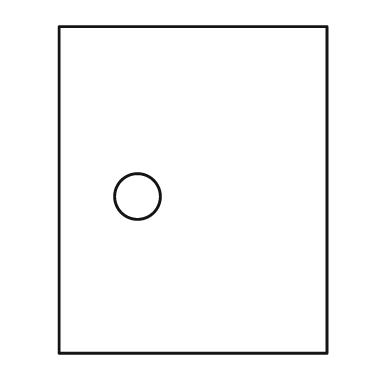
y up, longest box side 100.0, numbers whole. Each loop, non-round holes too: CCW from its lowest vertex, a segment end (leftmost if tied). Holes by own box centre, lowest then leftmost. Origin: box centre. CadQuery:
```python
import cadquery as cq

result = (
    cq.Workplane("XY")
    .moveTo(-41.0, -50.0)
    .lineTo(41.0, -50.0)
    .lineTo(41.0, 50.0)
    .lineTo(-41.0, 50.0)
    .close()
    .moveTo(-17.0, -2.0)
    .circle(7.0)
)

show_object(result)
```